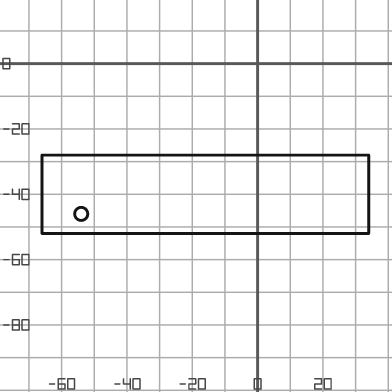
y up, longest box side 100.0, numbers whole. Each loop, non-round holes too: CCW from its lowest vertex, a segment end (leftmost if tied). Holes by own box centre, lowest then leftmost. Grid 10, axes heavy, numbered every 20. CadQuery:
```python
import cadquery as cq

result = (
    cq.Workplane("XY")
    .moveTo(-66.0, -52.0)
    .lineTo(34.0, -52.0)
    .lineTo(34.0, -28.0)
    .lineTo(-66.0, -28.0)
    .close()
    .moveTo(-54.0, -46.0)
    .circle(2.0)
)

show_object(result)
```